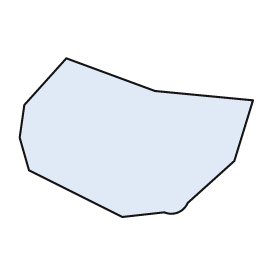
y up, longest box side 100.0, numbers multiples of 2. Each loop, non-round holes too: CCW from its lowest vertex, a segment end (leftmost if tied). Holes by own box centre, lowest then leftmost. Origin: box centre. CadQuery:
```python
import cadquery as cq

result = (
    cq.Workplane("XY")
    .moveTo(-6.0, -34.0)
    .lineTo(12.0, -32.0)
    .threePointArc((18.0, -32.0), (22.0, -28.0))
    .lineTo(42.0, -10.0)
    .lineTo(50.0, 16.0)
    .lineTo(8.0, 20.0)
    .lineTo(-30.0, 34.0)
    .lineTo(-48.0, 14.0)
    .lineTo(-50.0, 0.0)
    .lineTo(-46.0, -14.0)
    .close()
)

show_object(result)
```